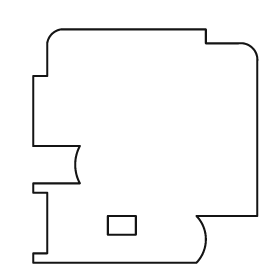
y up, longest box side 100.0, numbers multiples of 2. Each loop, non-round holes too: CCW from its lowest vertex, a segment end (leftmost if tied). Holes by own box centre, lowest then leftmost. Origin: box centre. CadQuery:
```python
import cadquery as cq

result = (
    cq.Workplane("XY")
    .moveTo(-48.0, -50.0)
    .lineTo(22.0, -50.0)
    .threePointArc((26.0, -40.0), (22.0, -30.0))
    .lineTo(48.0, -30.0)
    .lineTo(48.0, 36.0)
    .threePointArc((46.0, 42.0), (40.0, 44.0))
    .lineTo(26.0, 44.0)
    .lineTo(26.0, 50.0)
    .lineTo(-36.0, 50.0)
    .threePointArc((-40.0, 48.0), (-42.0, 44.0))
    .lineTo(-42.0, 30.0)
    .lineTo(-48.0, 30.0)
    .lineTo(-48.0, 0.0)
    .lineTo(-28.0, 0.0)
    .threePointArc((-30.0, -8.0), (-28.0, -16.0))
    .lineTo(-48.0, -16.0)
    .lineTo(-48.0, -20.0)
    .lineTo(-42.0, -20.0)
    .lineTo(-42.0, -46.0)
    .lineTo(-48.0, -46.0)
    .close()
    .moveTo(-16.0, -38.0)
    .lineTo(-4.0, -38.0)
    .lineTo(-4.0, -30.0)
    .lineTo(-16.0, -30.0)
    .close()
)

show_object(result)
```